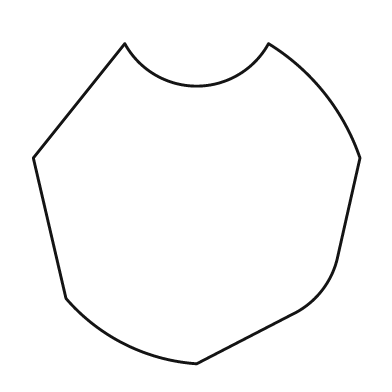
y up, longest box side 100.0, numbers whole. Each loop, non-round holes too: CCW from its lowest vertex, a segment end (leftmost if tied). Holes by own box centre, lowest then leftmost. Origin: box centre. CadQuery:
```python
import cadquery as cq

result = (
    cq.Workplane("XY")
    .moveTo(0.0, -49.0)
    .lineTo(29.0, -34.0)
    .threePointArc((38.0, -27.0), (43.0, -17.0))
    .lineTo(50.0, 14.0)
    .threePointArc((39.0, 34.0), (22.0, 49.0))
    .threePointArc((0.0, 36.0), (-22.0, 49.0))
    .lineTo(-50.0, 14.0)
    .lineTo(-40.0, -29.0)
    .threePointArc((-22.0, -43.0), (0.0, -49.0))
    .close()
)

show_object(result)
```